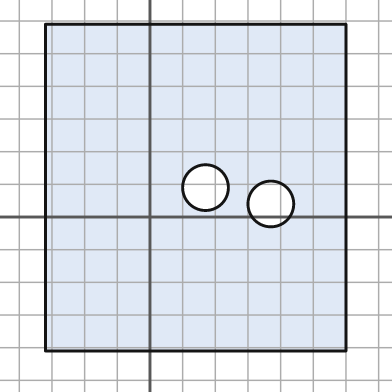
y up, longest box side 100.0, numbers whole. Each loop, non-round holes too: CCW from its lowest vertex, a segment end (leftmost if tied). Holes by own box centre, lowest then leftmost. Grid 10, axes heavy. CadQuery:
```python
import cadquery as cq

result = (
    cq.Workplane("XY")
    .moveTo(-32.0, -41.0)
    .lineTo(60.0, -41.0)
    .lineTo(60.0, 59.0)
    .lineTo(-32.0, 59.0)
    .close()
    .moveTo(37.0, 4.0)
    .circle(7.0)
    .moveTo(17.0, 9.0)
    .circle(7.0)
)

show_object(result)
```